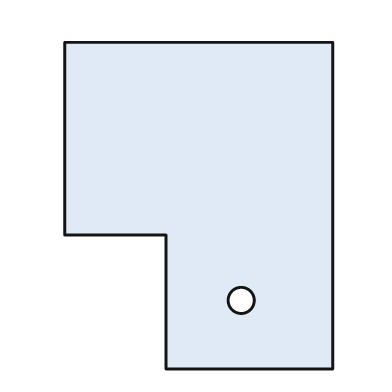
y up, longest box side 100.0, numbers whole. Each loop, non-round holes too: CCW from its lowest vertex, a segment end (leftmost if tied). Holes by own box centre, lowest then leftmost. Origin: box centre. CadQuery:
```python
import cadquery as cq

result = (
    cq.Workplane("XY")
    .moveTo(-10.0, -50.0)
    .lineTo(41.0, -50.0)
    .lineTo(41.0, 50.0)
    .lineTo(-41.0, 50.0)
    .lineTo(-41.0, -9.0)
    .lineTo(-10.0, -9.0)
    .close()
    .moveTo(13.0, -29.0)
    .circle(4.0)
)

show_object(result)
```